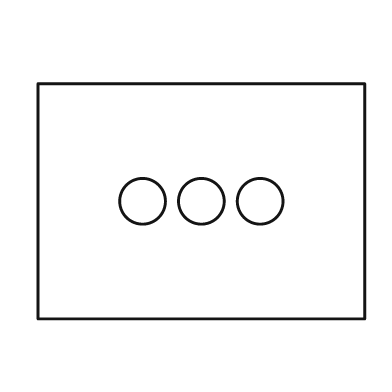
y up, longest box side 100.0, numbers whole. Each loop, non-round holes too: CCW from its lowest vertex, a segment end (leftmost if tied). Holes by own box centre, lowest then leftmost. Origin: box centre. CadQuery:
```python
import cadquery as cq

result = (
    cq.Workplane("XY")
    .moveTo(-50.0, -36.0)
    .lineTo(50.0, -36.0)
    .lineTo(50.0, 36.0)
    .lineTo(-50.0, 36.0)
    .close()
    .moveTo(-18.0, 0.0)
    .circle(7.0)
    .moveTo(0.0, 0.0)
    .circle(7.0)
    .moveTo(18.0, 0.0)
    .circle(7.0)
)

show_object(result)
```